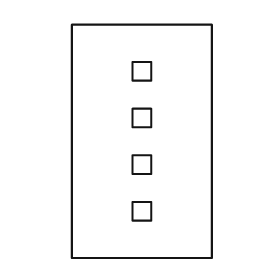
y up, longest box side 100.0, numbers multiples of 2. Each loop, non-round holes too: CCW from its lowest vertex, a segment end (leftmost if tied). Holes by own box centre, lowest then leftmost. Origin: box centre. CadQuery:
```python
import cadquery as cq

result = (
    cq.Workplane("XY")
    .moveTo(-30.0, -50.0)
    .lineTo(30.0, -50.0)
    .lineTo(30.0, 50.0)
    .lineTo(-30.0, 50.0)
    .close()
    .moveTo(-4.0, -34.0)
    .lineTo(4.0, -34.0)
    .lineTo(4.0, -26.0)
    .lineTo(-4.0, -26.0)
    .close()
    .moveTo(-4.0, -14.0)
    .lineTo(4.0, -14.0)
    .lineTo(4.0, -6.0)
    .lineTo(-4.0, -6.0)
    .close()
    .moveTo(-4.0, 6.0)
    .lineTo(4.0, 6.0)
    .lineTo(4.0, 14.0)
    .lineTo(-4.0, 14.0)
    .close()
    .moveTo(-4.0, 26.0)
    .lineTo(4.0, 26.0)
    .lineTo(4.0, 34.0)
    .lineTo(-4.0, 34.0)
    .close()
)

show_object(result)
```